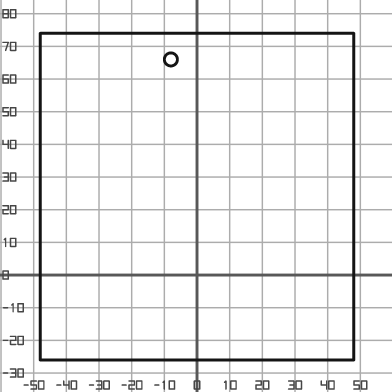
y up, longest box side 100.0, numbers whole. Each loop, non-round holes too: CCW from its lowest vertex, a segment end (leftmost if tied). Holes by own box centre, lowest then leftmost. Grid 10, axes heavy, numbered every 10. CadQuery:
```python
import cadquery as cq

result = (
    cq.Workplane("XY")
    .moveTo(-48.0, -26.0)
    .lineTo(48.0, -26.0)
    .lineTo(48.0, 74.0)
    .lineTo(-48.0, 74.0)
    .close()
    .moveTo(-8.0, 66.0)
    .circle(2.0)
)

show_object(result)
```